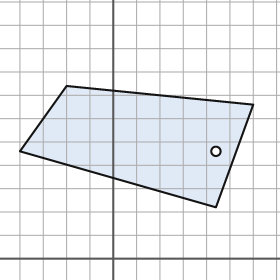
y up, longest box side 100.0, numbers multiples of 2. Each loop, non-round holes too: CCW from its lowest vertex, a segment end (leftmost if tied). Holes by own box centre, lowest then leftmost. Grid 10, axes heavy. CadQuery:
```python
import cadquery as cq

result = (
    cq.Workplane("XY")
    .moveTo(44.0, 22.0)
    .lineTo(60.0, 66.0)
    .lineTo(-20.0, 74.0)
    .lineTo(-40.0, 46.0)
    .close()
    .moveTo(44.0, 46.0)
    .circle(2.0)
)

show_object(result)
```